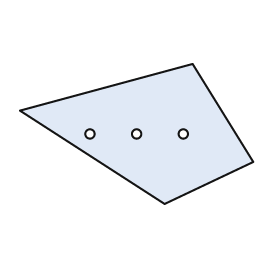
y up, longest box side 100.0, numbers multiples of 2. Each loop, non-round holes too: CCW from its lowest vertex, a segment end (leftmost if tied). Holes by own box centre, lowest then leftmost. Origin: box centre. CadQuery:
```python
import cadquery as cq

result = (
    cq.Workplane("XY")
    .moveTo(12.0, -30.0)
    .lineTo(50.0, -12.0)
    .lineTo(24.0, 30.0)
    .lineTo(-50.0, 10.0)
    .close()
    .moveTo(-20.0, 0.0)
    .circle(2.0)
    .moveTo(0.0, 0.0)
    .circle(2.0)
    .moveTo(20.0, 0.0)
    .circle(2.0)
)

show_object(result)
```